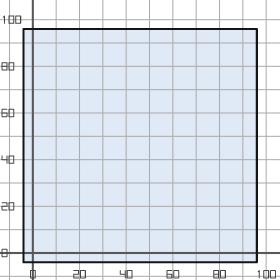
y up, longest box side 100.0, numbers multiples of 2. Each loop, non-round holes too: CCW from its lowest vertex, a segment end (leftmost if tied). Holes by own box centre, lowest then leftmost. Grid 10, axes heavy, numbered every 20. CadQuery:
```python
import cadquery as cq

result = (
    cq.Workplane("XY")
    .moveTo(-4.0, -4.0)
    .lineTo(96.0, -4.0)
    .lineTo(96.0, 96.0)
    .lineTo(-4.0, 96.0)
    .close()
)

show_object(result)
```